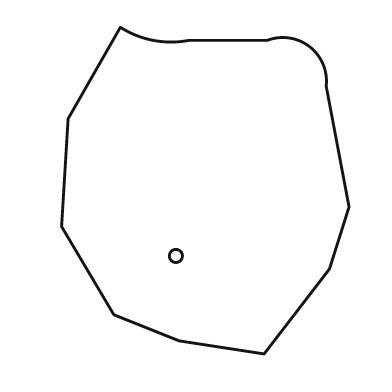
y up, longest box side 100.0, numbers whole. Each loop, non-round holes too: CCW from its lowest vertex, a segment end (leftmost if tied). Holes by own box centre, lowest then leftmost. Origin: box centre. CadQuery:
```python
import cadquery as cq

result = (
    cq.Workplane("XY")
    .moveTo(18.0, -50.0)
    .lineTo(38.0, -24.0)
    .lineTo(44.0, -5.0)
    .lineTo(37.0, 32.0)
    .threePointArc((32.0, 44.0), (19.0, 46.0))
    .lineTo(-5.0, 46.0)
    .threePointArc((-16.0, 46.0), (-26.0, 50.0))
    .lineTo(-42.0, 22.0)
    .lineTo(-44.0, -11.0)
    .lineTo(-28.0, -38.0)
    .lineTo(-8.0, -46.0)
    .close()
    .moveTo(-9.0, -20.0)
    .circle(2.0)
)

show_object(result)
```